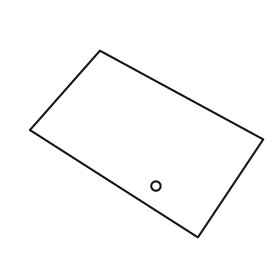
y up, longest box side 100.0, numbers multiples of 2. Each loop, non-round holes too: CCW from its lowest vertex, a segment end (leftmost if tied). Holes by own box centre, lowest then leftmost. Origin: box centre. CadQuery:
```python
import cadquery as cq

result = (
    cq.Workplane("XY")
    .moveTo(22.0, -40.0)
    .lineTo(50.0, 2.0)
    .lineTo(-20.0, 40.0)
    .lineTo(-50.0, 6.0)
    .close()
    .moveTo(4.0, -18.0)
    .circle(2.0)
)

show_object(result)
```